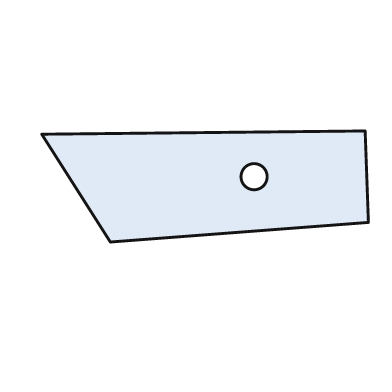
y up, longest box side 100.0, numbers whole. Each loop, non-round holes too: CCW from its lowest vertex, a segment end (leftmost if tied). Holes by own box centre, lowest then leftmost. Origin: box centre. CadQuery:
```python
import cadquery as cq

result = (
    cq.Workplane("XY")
    .moveTo(-29.0, -17.0)
    .lineTo(50.0, -11.0)
    .lineTo(49.0, 17.0)
    .lineTo(-50.0, 16.0)
    .close()
    .moveTo(15.0, 3.0)
    .circle(4.0)
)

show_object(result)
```